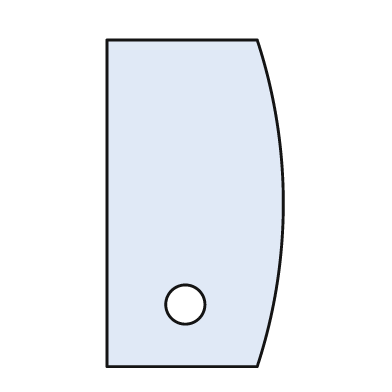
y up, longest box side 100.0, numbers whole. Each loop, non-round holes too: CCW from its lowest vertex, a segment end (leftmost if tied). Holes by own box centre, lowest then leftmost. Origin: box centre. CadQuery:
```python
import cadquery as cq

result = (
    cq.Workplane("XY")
    .moveTo(-27.0, -50.0)
    .lineTo(19.0, -50.0)
    .threePointArc((27.0, 0.0), (19.0, 50.0))
    .lineTo(-27.0, 50.0)
    .close()
    .moveTo(-3.0, -31.0)
    .circle(6.0)
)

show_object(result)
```